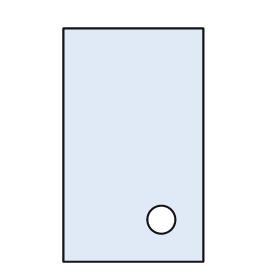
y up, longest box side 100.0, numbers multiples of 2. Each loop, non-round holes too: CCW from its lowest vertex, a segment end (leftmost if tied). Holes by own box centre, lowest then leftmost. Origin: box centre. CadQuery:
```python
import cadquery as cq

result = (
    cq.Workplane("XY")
    .moveTo(-30.0, -50.0)
    .lineTo(30.0, -50.0)
    .lineTo(30.0, 50.0)
    .lineTo(-30.0, 50.0)
    .close()
    .moveTo(12.0, -32.0)
    .circle(6.0)
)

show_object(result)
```